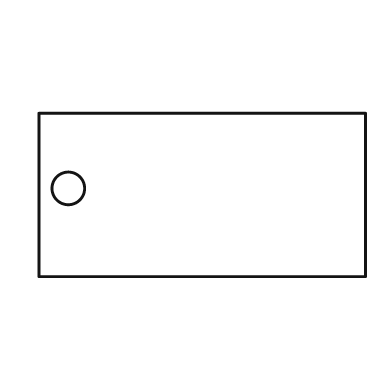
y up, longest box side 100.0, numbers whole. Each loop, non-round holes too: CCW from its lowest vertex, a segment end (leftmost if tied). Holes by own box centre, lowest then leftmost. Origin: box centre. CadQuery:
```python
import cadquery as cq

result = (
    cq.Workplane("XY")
    .moveTo(-50.0, -25.0)
    .lineTo(50.0, -25.0)
    .lineTo(50.0, 25.0)
    .lineTo(-50.0, 25.0)
    .close()
    .moveTo(-41.0, 2.0)
    .circle(5.0)
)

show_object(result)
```